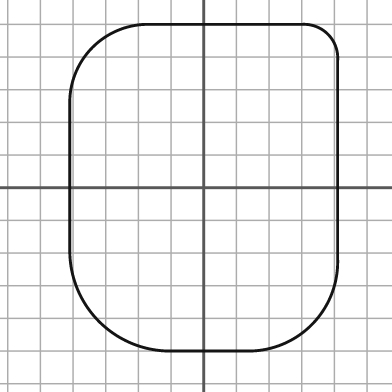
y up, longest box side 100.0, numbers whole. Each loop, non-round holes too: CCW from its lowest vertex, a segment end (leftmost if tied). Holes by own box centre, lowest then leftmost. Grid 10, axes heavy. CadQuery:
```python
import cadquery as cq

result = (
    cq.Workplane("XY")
    .moveTo(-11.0, -50.0)
    .lineTo(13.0, -50.0)
    .threePointArc((33.0, -42.0), (41.0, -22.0))
    .lineTo(41.0, 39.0)
    .threePointArc((38.0, 47.0), (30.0, 50.0))
    .lineTo(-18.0, 50.0)
    .threePointArc((-34.0, 43.0), (-41.0, 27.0))
    .lineTo(-41.0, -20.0)
    .threePointArc((-32.0, -41.0), (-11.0, -50.0))
    .close()
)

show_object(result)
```